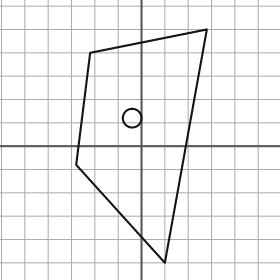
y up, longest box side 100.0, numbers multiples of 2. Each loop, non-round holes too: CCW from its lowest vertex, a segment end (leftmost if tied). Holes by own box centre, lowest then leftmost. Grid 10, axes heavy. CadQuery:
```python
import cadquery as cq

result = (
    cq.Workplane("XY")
    .moveTo(10.0, -50.0)
    .lineTo(28.0, 50.0)
    .lineTo(-22.0, 40.0)
    .lineTo(-28.0, -8.0)
    .close()
    .moveTo(-4.0, 12.0)
    .circle(4.0)
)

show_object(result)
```